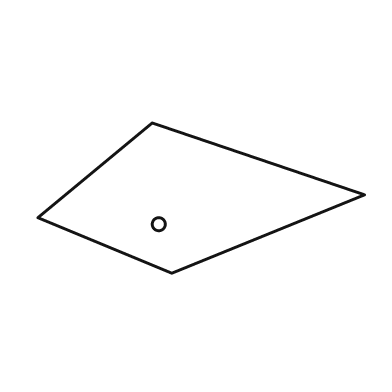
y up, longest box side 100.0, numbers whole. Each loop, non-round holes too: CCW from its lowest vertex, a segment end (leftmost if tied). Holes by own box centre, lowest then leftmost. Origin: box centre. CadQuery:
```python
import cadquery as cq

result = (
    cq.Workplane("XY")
    .moveTo(-9.0, -23.0)
    .lineTo(50.0, 1.0)
    .lineTo(-15.0, 23.0)
    .lineTo(-50.0, -6.0)
    .close()
    .moveTo(-13.0, -8.0)
    .circle(2.0)
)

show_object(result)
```